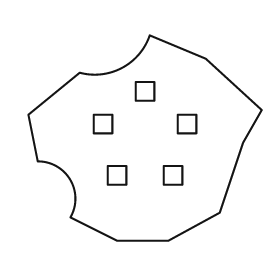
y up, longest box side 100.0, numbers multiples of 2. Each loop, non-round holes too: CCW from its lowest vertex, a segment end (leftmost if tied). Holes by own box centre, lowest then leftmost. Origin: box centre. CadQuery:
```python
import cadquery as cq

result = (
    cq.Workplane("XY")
    .moveTo(-12.0, -44.0)
    .lineTo(10.0, -44.0)
    .lineTo(32.0, -32.0)
    .lineTo(42.0, -2.0)
    .lineTo(50.0, 12.0)
    .lineTo(26.0, 34.0)
    .lineTo(2.0, 44.0)
    .threePointArc((-10.0, 30.0), (-28.0, 28.0))
    .lineTo(-50.0, 10.0)
    .lineTo(-46.0, -10.0)
    .threePointArc((-32.0, -18.0), (-32.0, -34.0))
    .close()
    .moveTo(-16.0, -20.0)
    .lineTo(-8.0, -20.0)
    .lineTo(-8.0, -12.0)
    .lineTo(-16.0, -12.0)
    .close()
    .moveTo(8.0, -20.0)
    .lineTo(16.0, -20.0)
    .lineTo(16.0, -12.0)
    .lineTo(8.0, -12.0)
    .close()
    .moveTo(-22.0, 2.0)
    .lineTo(-14.0, 2.0)
    .lineTo(-14.0, 10.0)
    .lineTo(-22.0, 10.0)
    .close()
    .moveTo(14.0, 2.0)
    .lineTo(22.0, 2.0)
    .lineTo(22.0, 10.0)
    .lineTo(14.0, 10.0)
    .close()
    .moveTo(-4.0, 16.0)
    .lineTo(4.0, 16.0)
    .lineTo(4.0, 24.0)
    .lineTo(-4.0, 24.0)
    .close()
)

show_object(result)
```